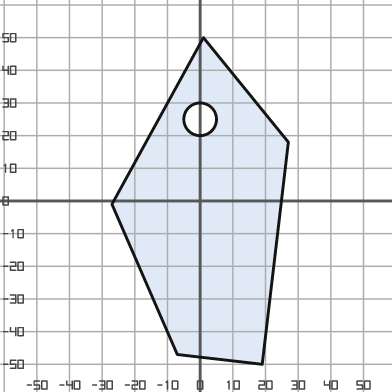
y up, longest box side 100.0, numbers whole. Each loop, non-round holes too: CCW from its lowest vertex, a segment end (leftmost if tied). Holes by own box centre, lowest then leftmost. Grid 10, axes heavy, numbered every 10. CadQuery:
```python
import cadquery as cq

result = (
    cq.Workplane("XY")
    .moveTo(19.0, -50.0)
    .lineTo(27.0, 18.0)
    .lineTo(1.0, 50.0)
    .lineTo(-27.0, -1.0)
    .lineTo(-7.0, -47.0)
    .close()
    .moveTo(0.0, 25.0)
    .circle(5.0)
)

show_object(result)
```